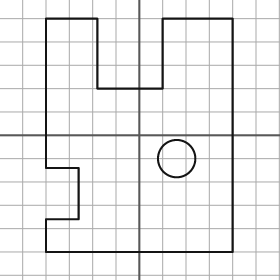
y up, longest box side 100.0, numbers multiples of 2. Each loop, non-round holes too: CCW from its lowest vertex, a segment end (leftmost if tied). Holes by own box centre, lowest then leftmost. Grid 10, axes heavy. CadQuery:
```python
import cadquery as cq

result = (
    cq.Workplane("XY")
    .moveTo(-40.0, -50.0)
    .lineTo(40.0, -50.0)
    .lineTo(40.0, 50.0)
    .lineTo(10.0, 50.0)
    .lineTo(10.0, 20.0)
    .lineTo(-18.0, 20.0)
    .lineTo(-18.0, 50.0)
    .lineTo(-40.0, 50.0)
    .lineTo(-40.0, -14.0)
    .lineTo(-26.0, -14.0)
    .lineTo(-26.0, -36.0)
    .lineTo(-40.0, -36.0)
    .close()
    .moveTo(16.0, -10.0)
    .circle(8.0)
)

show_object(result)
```